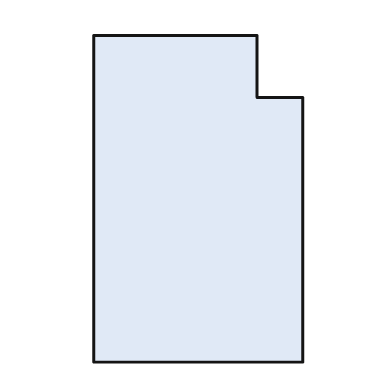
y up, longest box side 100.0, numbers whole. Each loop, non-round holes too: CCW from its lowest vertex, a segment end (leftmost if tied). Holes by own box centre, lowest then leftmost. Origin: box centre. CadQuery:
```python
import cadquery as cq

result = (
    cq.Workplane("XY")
    .moveTo(-32.0, -50.0)
    .lineTo(32.0, -50.0)
    .lineTo(32.0, 31.0)
    .lineTo(18.0, 31.0)
    .lineTo(18.0, 50.0)
    .lineTo(-32.0, 50.0)
    .close()
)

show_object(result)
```